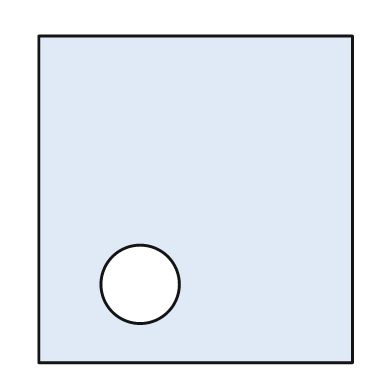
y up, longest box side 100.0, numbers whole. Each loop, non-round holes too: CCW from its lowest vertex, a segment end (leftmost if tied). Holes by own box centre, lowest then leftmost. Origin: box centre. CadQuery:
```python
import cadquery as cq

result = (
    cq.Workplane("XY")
    .moveTo(-48.0, -50.0)
    .lineTo(48.0, -50.0)
    .lineTo(48.0, 50.0)
    .lineTo(-48.0, 50.0)
    .close()
    .moveTo(-17.0, -26.0)
    .circle(12.0)
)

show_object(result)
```